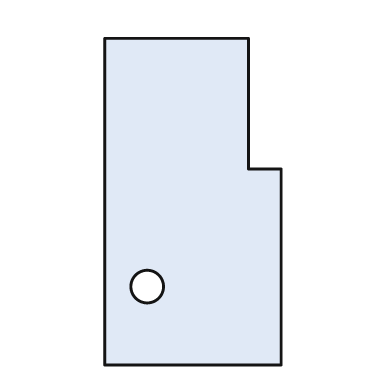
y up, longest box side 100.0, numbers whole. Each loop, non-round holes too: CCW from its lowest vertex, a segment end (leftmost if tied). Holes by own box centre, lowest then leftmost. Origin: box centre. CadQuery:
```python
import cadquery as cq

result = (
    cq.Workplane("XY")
    .moveTo(-27.0, -50.0)
    .lineTo(27.0, -50.0)
    .lineTo(27.0, 10.0)
    .lineTo(17.0, 10.0)
    .lineTo(17.0, 50.0)
    .lineTo(-27.0, 50.0)
    .close()
    .moveTo(-14.0, -26.0)
    .circle(5.0)
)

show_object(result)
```